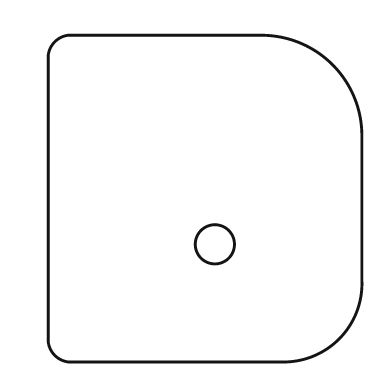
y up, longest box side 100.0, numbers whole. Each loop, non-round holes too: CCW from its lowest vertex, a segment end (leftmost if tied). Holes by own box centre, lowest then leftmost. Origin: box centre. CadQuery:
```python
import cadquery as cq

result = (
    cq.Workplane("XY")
    .moveTo(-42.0, -50.0)
    .lineTo(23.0, -50.0)
    .threePointArc((41.0, -43.0), (48.0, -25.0))
    .lineTo(48.0, 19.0)
    .threePointArc((39.0, 41.0), (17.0, 50.0))
    .lineTo(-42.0, 50.0)
    .threePointArc((-46.0, 48.0), (-48.0, 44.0))
    .lineTo(-48.0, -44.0)
    .threePointArc((-46.0, -48.0), (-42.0, -50.0))
    .close()
    .moveTo(3.0, -14.0)
    .circle(6.0)
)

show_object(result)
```